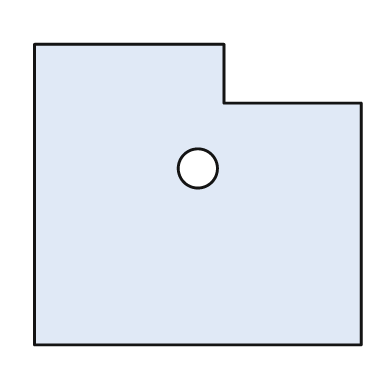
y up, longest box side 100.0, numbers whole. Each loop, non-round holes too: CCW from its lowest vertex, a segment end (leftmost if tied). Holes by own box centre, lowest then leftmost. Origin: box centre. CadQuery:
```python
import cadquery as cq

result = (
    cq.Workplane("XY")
    .moveTo(-50.0, -46.0)
    .lineTo(50.0, -46.0)
    .lineTo(50.0, 28.0)
    .lineTo(8.0, 28.0)
    .lineTo(8.0, 46.0)
    .lineTo(-50.0, 46.0)
    .close()
    .moveTo(0.0, 8.0)
    .circle(6.0)
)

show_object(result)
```